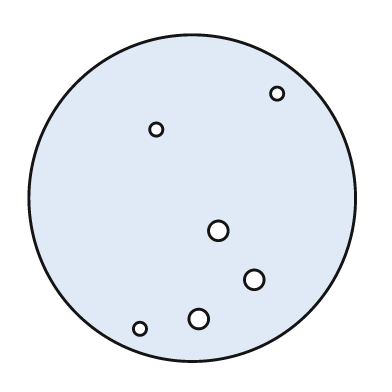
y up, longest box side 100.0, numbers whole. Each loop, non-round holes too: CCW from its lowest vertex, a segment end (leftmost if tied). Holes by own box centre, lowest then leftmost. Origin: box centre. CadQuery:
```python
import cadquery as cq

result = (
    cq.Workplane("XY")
    .moveTo(0.0, 0.0)
    .circle(50.0)
    .moveTo(-16.0, -40.0)
    .circle(2.0)
    .moveTo(2.0, -37.0)
    .circle(3.0)
    .moveTo(19.0, -25.0)
    .circle(3.0)
    .moveTo(8.0, -10.0)
    .circle(3.0)
    .moveTo(-11.0, 21.0)
    .circle(2.0)
    .moveTo(26.0, 32.0)
    .circle(2.0)
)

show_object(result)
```